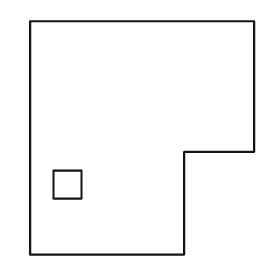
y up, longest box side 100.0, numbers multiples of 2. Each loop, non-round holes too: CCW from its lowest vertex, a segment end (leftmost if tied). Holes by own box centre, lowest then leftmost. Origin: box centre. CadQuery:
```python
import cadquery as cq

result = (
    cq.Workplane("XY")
    .moveTo(-48.0, -50.0)
    .lineTo(18.0, -50.0)
    .lineTo(18.0, -6.0)
    .lineTo(48.0, -6.0)
    .lineTo(48.0, 50.0)
    .lineTo(-48.0, 50.0)
    .close()
    .moveTo(-38.0, -26.0)
    .lineTo(-26.0, -26.0)
    .lineTo(-26.0, -14.0)
    .lineTo(-38.0, -14.0)
    .close()
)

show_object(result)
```